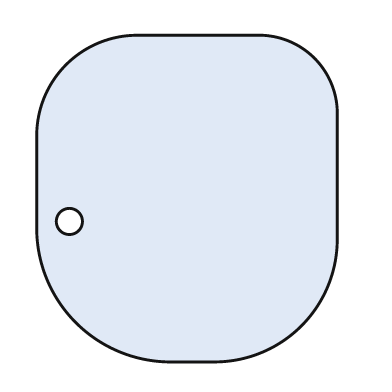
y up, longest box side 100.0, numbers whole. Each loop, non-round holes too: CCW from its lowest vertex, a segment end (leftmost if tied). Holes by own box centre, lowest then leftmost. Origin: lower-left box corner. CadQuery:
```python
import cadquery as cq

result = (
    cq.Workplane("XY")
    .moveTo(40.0, 0.0)
    .lineTo(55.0, 0.0)
    .threePointArc((81.0, 11.0), (92.0, 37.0))
    .lineTo(92.0, 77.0)
    .threePointArc((85.0, 93.0), (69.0, 100.0))
    .lineTo(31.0, 100.0)
    .threePointArc((9.0, 91.0), (0.0, 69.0))
    .lineTo(0.0, 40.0)
    .threePointArc((12.0, 12.0), (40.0, 0.0))
    .close()
    .moveTo(10.0, 43.0)
    .circle(4.0)
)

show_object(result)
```